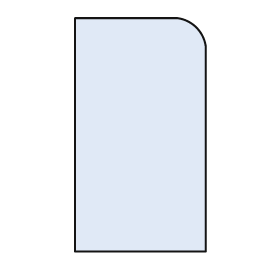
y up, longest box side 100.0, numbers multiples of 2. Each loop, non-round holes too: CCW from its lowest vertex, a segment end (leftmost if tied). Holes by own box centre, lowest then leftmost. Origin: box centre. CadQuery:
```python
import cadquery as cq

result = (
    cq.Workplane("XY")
    .moveTo(-28.0, -50.0)
    .lineTo(28.0, -50.0)
    .lineTo(28.0, 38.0)
    .threePointArc((24.0, 46.0), (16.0, 50.0))
    .lineTo(-28.0, 50.0)
    .close()
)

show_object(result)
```